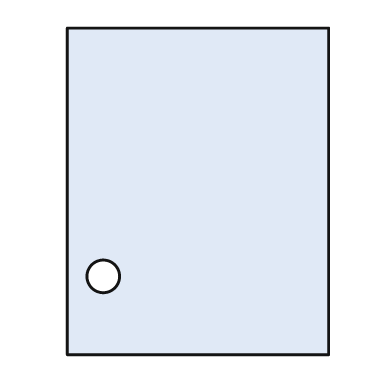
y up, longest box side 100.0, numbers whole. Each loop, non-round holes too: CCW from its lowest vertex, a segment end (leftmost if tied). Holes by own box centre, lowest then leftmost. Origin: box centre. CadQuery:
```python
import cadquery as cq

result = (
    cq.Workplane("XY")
    .moveTo(-40.0, -50.0)
    .lineTo(40.0, -50.0)
    .lineTo(40.0, 50.0)
    .lineTo(-40.0, 50.0)
    .close()
    .moveTo(-29.0, -26.0)
    .circle(5.0)
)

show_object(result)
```